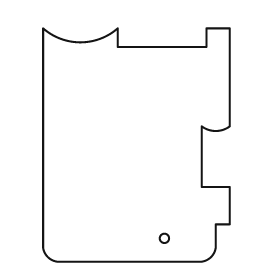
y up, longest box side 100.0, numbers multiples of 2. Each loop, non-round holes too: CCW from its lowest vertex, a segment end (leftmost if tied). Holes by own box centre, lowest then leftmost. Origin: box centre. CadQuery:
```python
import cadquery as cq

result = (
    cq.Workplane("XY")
    .moveTo(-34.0, -50.0)
    .lineTo(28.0, -50.0)
    .threePointArc((32.0, -48.0), (34.0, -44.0))
    .lineTo(34.0, -34.0)
    .lineTo(40.0, -34.0)
    .lineTo(40.0, -18.0)
    .lineTo(28.0, -18.0)
    .lineTo(28.0, 8.0)
    .threePointArc((34.0, 6.0), (40.0, 8.0))
    .lineTo(40.0, 50.0)
    .lineTo(30.0, 50.0)
    .lineTo(30.0, 42.0)
    .lineTo(-8.0, 42.0)
    .lineTo(-8.0, 50.0)
    .threePointArc((-24.0, 44.0), (-40.0, 50.0))
    .lineTo(-40.0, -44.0)
    .threePointArc((-38.0, -48.0), (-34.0, -50.0))
    .close()
    .moveTo(12.0, -40.0)
    .circle(2.0)
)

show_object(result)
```